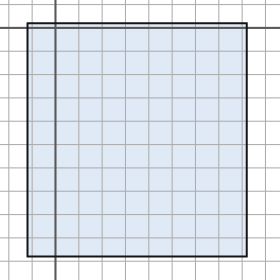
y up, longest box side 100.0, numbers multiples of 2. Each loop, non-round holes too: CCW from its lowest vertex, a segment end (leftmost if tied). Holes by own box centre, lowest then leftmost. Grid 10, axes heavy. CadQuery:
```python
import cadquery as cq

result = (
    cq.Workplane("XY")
    .moveTo(-12.0, -98.0)
    .lineTo(82.0, -98.0)
    .lineTo(82.0, 2.0)
    .lineTo(-12.0, 2.0)
    .close()
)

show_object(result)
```